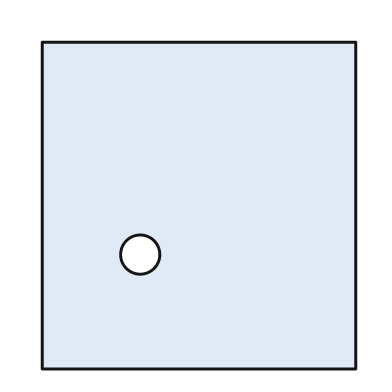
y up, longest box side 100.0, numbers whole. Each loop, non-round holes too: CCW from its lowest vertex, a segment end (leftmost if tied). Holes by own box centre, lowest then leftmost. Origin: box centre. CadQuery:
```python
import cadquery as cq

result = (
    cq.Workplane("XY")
    .moveTo(-48.0, -50.0)
    .lineTo(48.0, -50.0)
    .lineTo(48.0, 50.0)
    .lineTo(-48.0, 50.0)
    .close()
    .moveTo(-18.0, -15.0)
    .circle(6.0)
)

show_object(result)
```